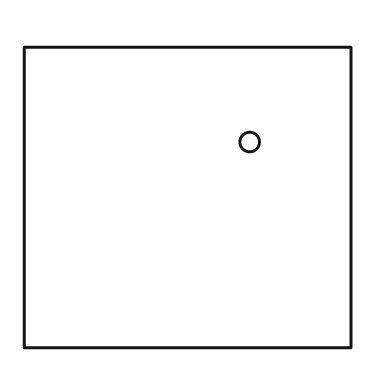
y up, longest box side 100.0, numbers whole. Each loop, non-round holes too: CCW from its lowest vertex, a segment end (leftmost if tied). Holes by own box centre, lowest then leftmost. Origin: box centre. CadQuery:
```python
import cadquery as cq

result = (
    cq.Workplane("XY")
    .moveTo(-50.0, -46.0)
    .lineTo(50.0, -46.0)
    .lineTo(50.0, 46.0)
    .lineTo(-50.0, 46.0)
    .close()
    .moveTo(19.0, 17.0)
    .circle(3.0)
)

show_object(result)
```